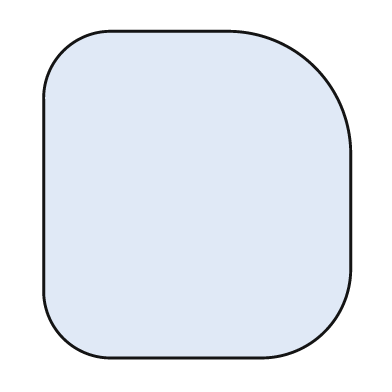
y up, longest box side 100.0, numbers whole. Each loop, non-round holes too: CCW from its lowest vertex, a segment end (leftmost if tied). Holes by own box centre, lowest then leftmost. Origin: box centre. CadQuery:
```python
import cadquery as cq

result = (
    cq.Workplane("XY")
    .moveTo(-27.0, -50.0)
    .lineTo(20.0, -50.0)
    .threePointArc((39.0, -42.0), (47.0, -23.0))
    .lineTo(47.0, 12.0)
    .threePointArc((36.0, 39.0), (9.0, 50.0))
    .lineTo(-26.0, 50.0)
    .threePointArc((-41.0, 44.0), (-47.0, 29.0))
    .lineTo(-47.0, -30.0)
    .threePointArc((-41.0, -44.0), (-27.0, -50.0))
    .close()
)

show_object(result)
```